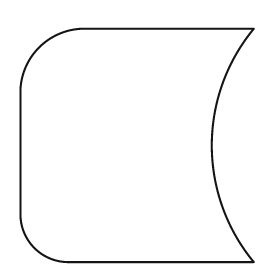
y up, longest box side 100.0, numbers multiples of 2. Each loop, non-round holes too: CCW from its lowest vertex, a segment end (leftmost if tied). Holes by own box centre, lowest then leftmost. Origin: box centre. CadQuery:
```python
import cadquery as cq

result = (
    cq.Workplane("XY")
    .moveTo(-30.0, -50.0)
    .lineTo(50.0, -50.0)
    .threePointArc((32.0, 0.0), (50.0, 50.0))
    .lineTo(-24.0, 50.0)
    .threePointArc((-42.0, 42.0), (-50.0, 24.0))
    .lineTo(-50.0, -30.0)
    .threePointArc((-44.0, -44.0), (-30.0, -50.0))
    .close()
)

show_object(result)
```